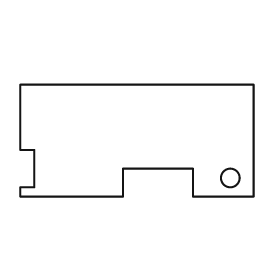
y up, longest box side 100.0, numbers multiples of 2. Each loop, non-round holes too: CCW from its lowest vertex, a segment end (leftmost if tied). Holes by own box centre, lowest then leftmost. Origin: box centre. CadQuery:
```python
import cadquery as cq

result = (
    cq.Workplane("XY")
    .moveTo(-50.0, -24.0)
    .lineTo(-6.0, -24.0)
    .lineTo(-6.0, -12.0)
    .lineTo(24.0, -12.0)
    .lineTo(24.0, -24.0)
    .lineTo(50.0, -24.0)
    .lineTo(50.0, 24.0)
    .lineTo(-50.0, 24.0)
    .lineTo(-50.0, -4.0)
    .lineTo(-44.0, -4.0)
    .lineTo(-44.0, -20.0)
    .lineTo(-50.0, -20.0)
    .close()
    .moveTo(40.0, -16.0)
    .circle(4.0)
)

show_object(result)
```